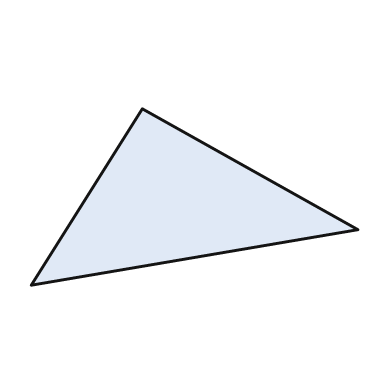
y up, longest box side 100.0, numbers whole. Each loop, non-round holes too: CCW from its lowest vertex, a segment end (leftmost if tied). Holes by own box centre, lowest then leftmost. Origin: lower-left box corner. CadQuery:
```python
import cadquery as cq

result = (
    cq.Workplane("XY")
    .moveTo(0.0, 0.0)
    .lineTo(100.0, 17.0)
    .lineTo(34.0, 54.0)
    .close()
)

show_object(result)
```